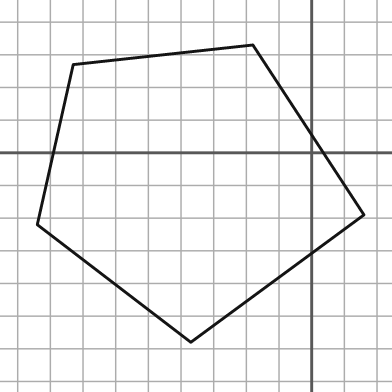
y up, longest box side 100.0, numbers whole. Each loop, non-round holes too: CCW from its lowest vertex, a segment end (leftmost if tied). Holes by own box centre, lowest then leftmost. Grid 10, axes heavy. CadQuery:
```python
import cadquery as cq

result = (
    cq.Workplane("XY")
    .moveTo(-37.0, -58.0)
    .lineTo(16.0, -19.0)
    .lineTo(-18.0, 33.0)
    .lineTo(-73.0, 27.0)
    .lineTo(-84.0, -22.0)
    .close()
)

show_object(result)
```